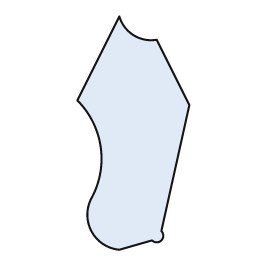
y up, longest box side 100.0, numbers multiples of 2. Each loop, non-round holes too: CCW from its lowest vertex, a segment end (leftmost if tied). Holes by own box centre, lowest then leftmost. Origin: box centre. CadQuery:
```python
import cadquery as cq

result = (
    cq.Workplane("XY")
    .moveTo(-6.0, -50.0)
    .lineTo(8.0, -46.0)
    .threePointArc((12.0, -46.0), (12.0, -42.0))
    .lineTo(24.0, 12.0)
    .lineTo(10.0, 40.0)
    .threePointArc((0.0, 42.0), (-6.0, 50.0))
    .lineTo(-24.0, 14.0)
    .threePointArc((-14.0, -6.0), (-18.0, -28.0))
    .threePointArc((-18.0, -42.0), (-6.0, -50.0))
    .close()
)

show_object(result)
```